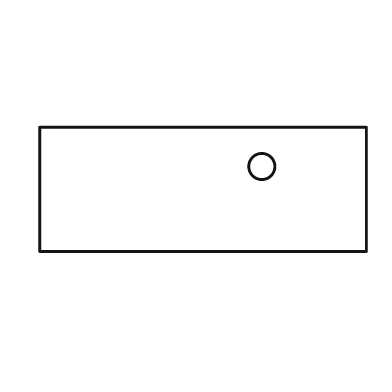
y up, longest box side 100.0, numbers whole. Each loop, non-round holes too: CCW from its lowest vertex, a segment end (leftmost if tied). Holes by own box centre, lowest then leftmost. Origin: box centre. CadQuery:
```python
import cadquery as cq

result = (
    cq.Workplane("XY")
    .moveTo(-50.0, -19.0)
    .lineTo(50.0, -19.0)
    .lineTo(50.0, 19.0)
    .lineTo(-50.0, 19.0)
    .close()
    .moveTo(18.0, 7.0)
    .circle(4.0)
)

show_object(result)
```